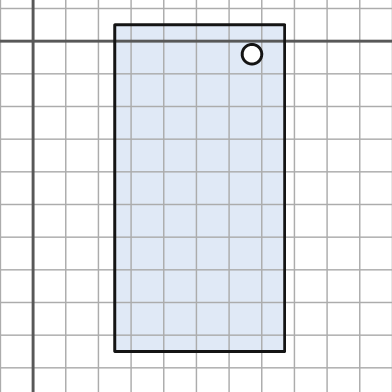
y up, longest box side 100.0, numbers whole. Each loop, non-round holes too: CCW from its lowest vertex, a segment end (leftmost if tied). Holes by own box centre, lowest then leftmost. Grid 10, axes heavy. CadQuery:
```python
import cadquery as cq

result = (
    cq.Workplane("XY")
    .moveTo(25.0, -95.0)
    .lineTo(77.0, -95.0)
    .lineTo(77.0, 5.0)
    .lineTo(25.0, 5.0)
    .close()
    .moveTo(67.0, -4.0)
    .circle(3.0)
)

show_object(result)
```